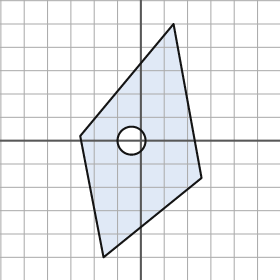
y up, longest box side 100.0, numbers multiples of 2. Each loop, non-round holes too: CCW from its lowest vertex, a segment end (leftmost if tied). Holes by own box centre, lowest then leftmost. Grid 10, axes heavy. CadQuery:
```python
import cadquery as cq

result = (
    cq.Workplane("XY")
    .moveTo(-16.0, -50.0)
    .lineTo(26.0, -16.0)
    .lineTo(14.0, 50.0)
    .lineTo(-26.0, 2.0)
    .close()
    .moveTo(-4.0, 0.0)
    .circle(6.0)
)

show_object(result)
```